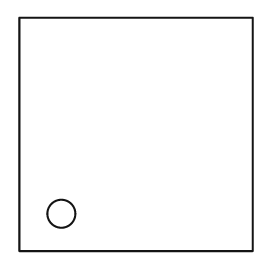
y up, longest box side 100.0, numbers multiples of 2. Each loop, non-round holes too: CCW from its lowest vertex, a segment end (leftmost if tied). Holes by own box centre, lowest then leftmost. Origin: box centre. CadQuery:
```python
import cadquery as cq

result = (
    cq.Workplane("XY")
    .moveTo(-50.0, -50.0)
    .lineTo(50.0, -50.0)
    .lineTo(50.0, 50.0)
    .lineTo(-50.0, 50.0)
    .close()
    .moveTo(-32.0, -34.0)
    .circle(6.0)
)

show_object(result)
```